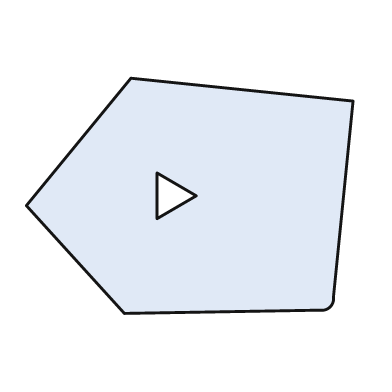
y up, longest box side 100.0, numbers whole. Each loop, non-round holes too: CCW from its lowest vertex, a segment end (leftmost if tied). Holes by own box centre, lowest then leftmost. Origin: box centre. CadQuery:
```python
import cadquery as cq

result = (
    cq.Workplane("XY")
    .moveTo(-20.0, -36.0)
    .lineTo(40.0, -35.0)
    .threePointArc((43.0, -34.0), (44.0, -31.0))
    .lineTo(50.0, 29.0)
    .lineTo(-18.0, 36.0)
    .lineTo(-50.0, -3.0)
    .close()
    .moveTo(-10.0, -7.0)
    .lineTo(2.0, 0.0)
    .lineTo(-10.0, 7.0)
    .close()
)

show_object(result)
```